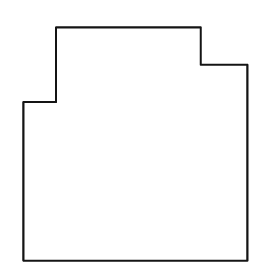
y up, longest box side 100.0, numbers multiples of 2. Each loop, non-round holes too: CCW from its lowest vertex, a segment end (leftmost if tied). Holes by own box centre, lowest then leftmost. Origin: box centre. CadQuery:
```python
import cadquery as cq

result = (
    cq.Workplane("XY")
    .moveTo(-48.0, -50.0)
    .lineTo(48.0, -50.0)
    .lineTo(48.0, 34.0)
    .lineTo(28.0, 34.0)
    .lineTo(28.0, 50.0)
    .lineTo(-34.0, 50.0)
    .lineTo(-34.0, 18.0)
    .lineTo(-48.0, 18.0)
    .close()
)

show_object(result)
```